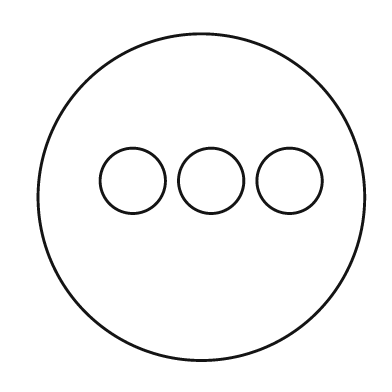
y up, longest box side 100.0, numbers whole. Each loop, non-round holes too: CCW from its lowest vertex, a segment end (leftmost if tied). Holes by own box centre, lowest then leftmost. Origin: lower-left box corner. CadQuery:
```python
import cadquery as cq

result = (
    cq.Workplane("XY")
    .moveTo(50.0, 50.0)
    .circle(50.0)
    .moveTo(29.0, 55.0)
    .circle(10.0)
    .moveTo(53.0, 55.0)
    .circle(10.0)
    .moveTo(77.0, 55.0)
    .circle(10.0)
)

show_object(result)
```